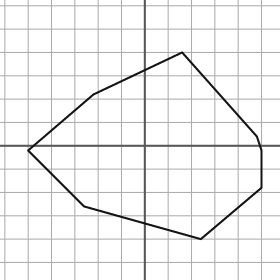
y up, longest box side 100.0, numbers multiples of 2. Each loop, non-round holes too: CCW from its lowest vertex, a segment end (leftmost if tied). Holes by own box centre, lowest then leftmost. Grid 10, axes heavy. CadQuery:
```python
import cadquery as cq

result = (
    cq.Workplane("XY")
    .moveTo(24.0, -40.0)
    .lineTo(50.0, -18.0)
    .lineTo(50.0, -2.0)
    .lineTo(48.0, 4.0)
    .lineTo(16.0, 40.0)
    .lineTo(-22.0, 22.0)
    .lineTo(-50.0, -2.0)
    .lineTo(-26.0, -26.0)
    .close()
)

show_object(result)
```